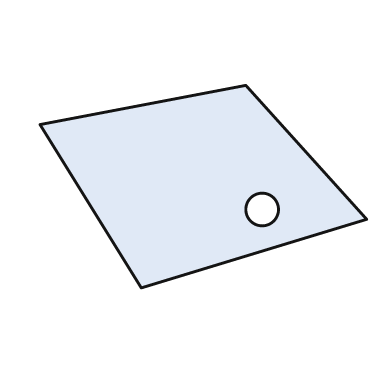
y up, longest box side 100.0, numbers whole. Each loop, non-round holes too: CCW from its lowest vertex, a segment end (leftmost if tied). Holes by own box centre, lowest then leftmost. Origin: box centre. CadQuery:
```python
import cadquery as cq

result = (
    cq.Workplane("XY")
    .moveTo(-19.0, -31.0)
    .lineTo(50.0, -10.0)
    .lineTo(13.0, 31.0)
    .lineTo(-50.0, 19.0)
    .close()
    .moveTo(18.0, -7.0)
    .circle(5.0)
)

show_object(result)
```